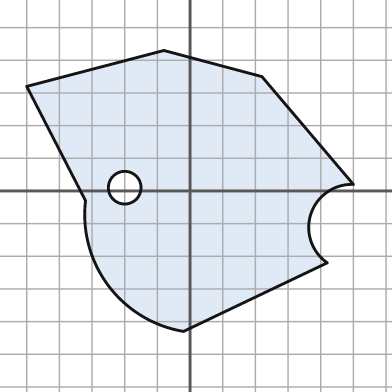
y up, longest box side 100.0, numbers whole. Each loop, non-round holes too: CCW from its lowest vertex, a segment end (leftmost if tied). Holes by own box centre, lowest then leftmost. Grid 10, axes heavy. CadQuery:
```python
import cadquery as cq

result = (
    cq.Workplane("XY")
    .moveTo(-2.0, -43.0)
    .lineTo(42.0, -22.0)
    .threePointArc((37.0, -7.0), (50.0, 2.0))
    .lineTo(22.0, 35.0)
    .lineTo(-8.0, 43.0)
    .lineTo(-50.0, 32.0)
    .lineTo(-32.0, -3.0)
    .threePointArc((-25.0, -29.0), (-2.0, -43.0))
    .close()
    .moveTo(-20.0, 1.0)
    .circle(5.0)
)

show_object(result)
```